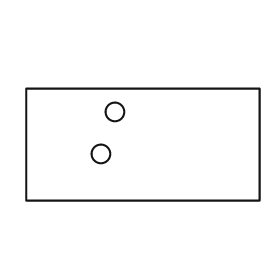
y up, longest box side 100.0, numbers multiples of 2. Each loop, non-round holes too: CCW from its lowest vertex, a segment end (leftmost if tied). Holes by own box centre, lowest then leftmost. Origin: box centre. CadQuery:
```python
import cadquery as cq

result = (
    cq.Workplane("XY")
    .moveTo(-50.0, -24.0)
    .lineTo(50.0, -24.0)
    .lineTo(50.0, 24.0)
    .lineTo(-50.0, 24.0)
    .close()
    .moveTo(-18.0, -4.0)
    .circle(4.0)
    .moveTo(-12.0, 14.0)
    .circle(4.0)
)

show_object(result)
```